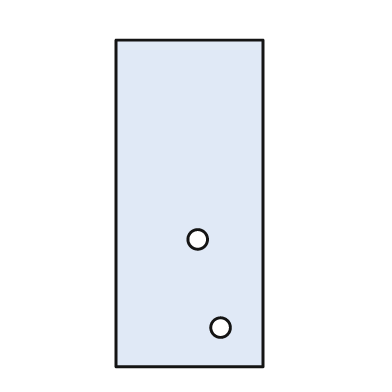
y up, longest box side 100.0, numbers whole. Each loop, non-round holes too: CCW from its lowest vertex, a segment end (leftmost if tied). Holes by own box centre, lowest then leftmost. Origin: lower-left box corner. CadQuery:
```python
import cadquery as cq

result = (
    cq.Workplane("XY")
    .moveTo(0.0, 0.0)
    .lineTo(45.0, 0.0)
    .lineTo(45.0, 100.0)
    .lineTo(0.0, 100.0)
    .close()
    .moveTo(32.0, 12.0)
    .circle(3.0)
    .moveTo(25.0, 39.0)
    .circle(3.0)
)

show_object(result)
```